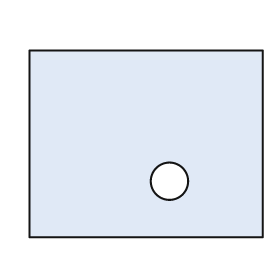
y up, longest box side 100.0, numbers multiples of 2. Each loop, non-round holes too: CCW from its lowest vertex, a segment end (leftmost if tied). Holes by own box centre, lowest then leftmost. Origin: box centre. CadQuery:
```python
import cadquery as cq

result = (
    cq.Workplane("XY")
    .moveTo(-50.0, -40.0)
    .lineTo(50.0, -40.0)
    .lineTo(50.0, 40.0)
    .lineTo(-50.0, 40.0)
    .close()
    .moveTo(10.0, -16.0)
    .circle(8.0)
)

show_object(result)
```